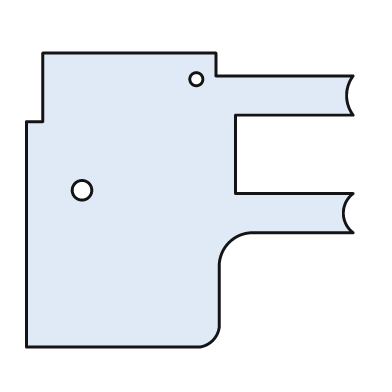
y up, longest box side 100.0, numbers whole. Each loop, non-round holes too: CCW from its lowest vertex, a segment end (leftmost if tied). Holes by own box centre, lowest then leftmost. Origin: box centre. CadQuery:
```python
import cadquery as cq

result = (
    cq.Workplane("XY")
    .moveTo(-50.0, -45.0)
    .lineTo(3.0, -45.0)
    .threePointArc((7.0, -43.0), (9.0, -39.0))
    .lineTo(9.0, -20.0)
    .threePointArc((12.0, -13.0), (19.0, -10.0))
    .lineTo(50.0, -10.0)
    .threePointArc((47.0, -4.0), (50.0, 2.0))
    .lineTo(14.0, 2.0)
    .lineTo(14.0, 26.0)
    .lineTo(50.0, 26.0)
    .threePointArc((48.0, 32.0), (50.0, 38.0))
    .lineTo(8.0, 38.0)
    .lineTo(8.0, 45.0)
    .lineTo(-45.0, 45.0)
    .lineTo(-45.0, 24.0)
    .lineTo(-50.0, 24.0)
    .close()
    .moveTo(-33.0, 3.0)
    .circle(3.0)
    .moveTo(2.0, 37.0)
    .circle(2.0)
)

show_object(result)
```